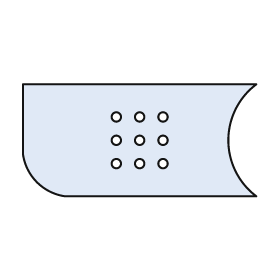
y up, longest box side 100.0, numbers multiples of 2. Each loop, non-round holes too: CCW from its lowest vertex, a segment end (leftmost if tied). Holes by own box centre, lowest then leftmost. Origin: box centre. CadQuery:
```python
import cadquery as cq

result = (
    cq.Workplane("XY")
    .moveTo(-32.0, -24.0)
    .lineTo(50.0, -24.0)
    .threePointArc((38.0, 0.0), (50.0, 24.0))
    .lineTo(-50.0, 24.0)
    .lineTo(-50.0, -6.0)
    .threePointArc((-44.0, -18.0), (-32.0, -24.0))
    .close()
    .moveTo(-10.0, -10.0)
    .circle(2.0)
    .moveTo(0.0, -10.0)
    .circle(2.0)
    .moveTo(10.0, -10.0)
    .circle(2.0)
    .moveTo(-10.0, 0.0)
    .circle(2.0)
    .moveTo(0.0, 0.0)
    .circle(2.0)
    .moveTo(10.0, 0.0)
    .circle(2.0)
    .moveTo(-10.0, 10.0)
    .circle(2.0)
    .moveTo(0.0, 10.0)
    .circle(2.0)
    .moveTo(10.0, 10.0)
    .circle(2.0)
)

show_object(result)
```